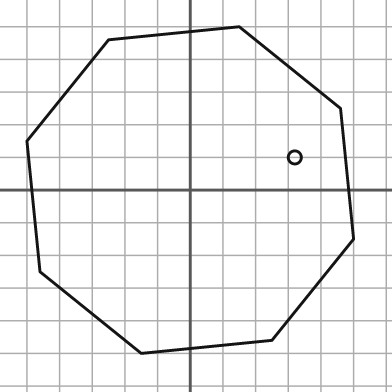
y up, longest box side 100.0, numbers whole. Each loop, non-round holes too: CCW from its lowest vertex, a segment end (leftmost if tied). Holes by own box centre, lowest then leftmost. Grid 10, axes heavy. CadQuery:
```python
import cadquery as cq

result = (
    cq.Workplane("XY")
    .moveTo(-15.0, -50.0)
    .lineTo(25.0, -46.0)
    .lineTo(50.0, -15.0)
    .lineTo(46.0, 25.0)
    .lineTo(15.0, 50.0)
    .lineTo(-25.0, 46.0)
    .lineTo(-50.0, 15.0)
    .lineTo(-46.0, -25.0)
    .close()
    .moveTo(32.0, 10.0)
    .circle(2.0)
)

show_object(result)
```